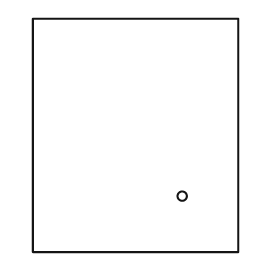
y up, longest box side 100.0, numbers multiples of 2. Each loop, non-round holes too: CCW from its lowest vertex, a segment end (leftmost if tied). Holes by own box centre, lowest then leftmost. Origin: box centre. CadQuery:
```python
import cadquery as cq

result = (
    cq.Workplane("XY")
    .moveTo(-44.0, -50.0)
    .lineTo(44.0, -50.0)
    .lineTo(44.0, 50.0)
    .lineTo(-44.0, 50.0)
    .close()
    .moveTo(20.0, -26.0)
    .circle(2.0)
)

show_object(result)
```